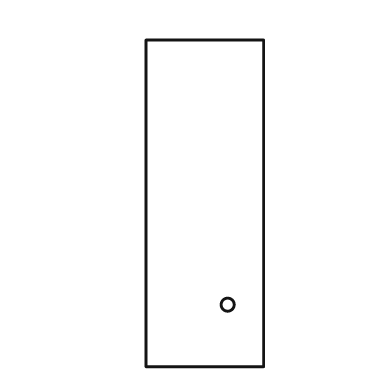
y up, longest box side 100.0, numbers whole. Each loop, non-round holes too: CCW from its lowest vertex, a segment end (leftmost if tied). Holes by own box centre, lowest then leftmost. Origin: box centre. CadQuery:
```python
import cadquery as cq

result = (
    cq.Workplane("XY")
    .moveTo(-18.0, -50.0)
    .lineTo(18.0, -50.0)
    .lineTo(18.0, 50.0)
    .lineTo(-18.0, 50.0)
    .close()
    .moveTo(7.0, -31.0)
    .circle(2.0)
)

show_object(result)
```